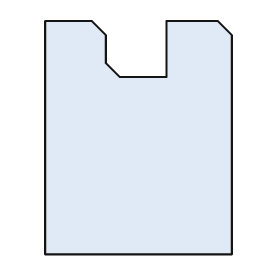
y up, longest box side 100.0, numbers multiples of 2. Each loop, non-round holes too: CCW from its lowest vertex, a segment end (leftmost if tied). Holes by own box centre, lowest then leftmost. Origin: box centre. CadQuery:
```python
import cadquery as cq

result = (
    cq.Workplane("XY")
    .moveTo(-40.0, -50.0)
    .lineTo(40.0, -50.0)
    .lineTo(40.0, 44.0)
    .lineTo(34.0, 50.0)
    .lineTo(12.0, 50.0)
    .lineTo(12.0, 26.0)
    .lineTo(-8.0, 26.0)
    .lineTo(-14.0, 32.0)
    .lineTo(-14.0, 44.0)
    .lineTo(-20.0, 50.0)
    .lineTo(-40.0, 50.0)
    .close()
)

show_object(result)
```